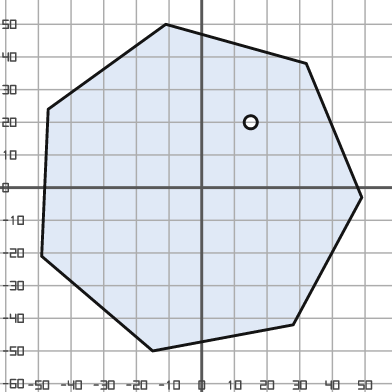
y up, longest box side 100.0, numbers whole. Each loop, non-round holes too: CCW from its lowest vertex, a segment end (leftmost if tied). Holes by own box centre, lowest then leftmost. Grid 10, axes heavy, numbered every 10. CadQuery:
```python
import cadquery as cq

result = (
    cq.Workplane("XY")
    .moveTo(-15.0, -50.0)
    .lineTo(28.0, -42.0)
    .lineTo(49.0, -3.0)
    .lineTo(32.0, 38.0)
    .lineTo(-11.0, 50.0)
    .lineTo(-47.0, 24.0)
    .lineTo(-49.0, -21.0)
    .close()
    .moveTo(15.0, 20.0)
    .circle(2.0)
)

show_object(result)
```